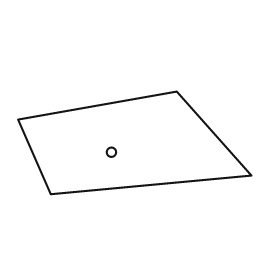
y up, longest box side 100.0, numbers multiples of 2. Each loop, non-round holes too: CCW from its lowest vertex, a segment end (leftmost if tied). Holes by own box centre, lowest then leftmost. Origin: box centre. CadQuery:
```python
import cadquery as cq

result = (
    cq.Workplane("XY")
    .moveTo(-36.0, -22.0)
    .lineTo(50.0, -14.0)
    .lineTo(18.0, 22.0)
    .lineTo(-50.0, 10.0)
    .close()
    .moveTo(-10.0, -4.0)
    .circle(2.0)
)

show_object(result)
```